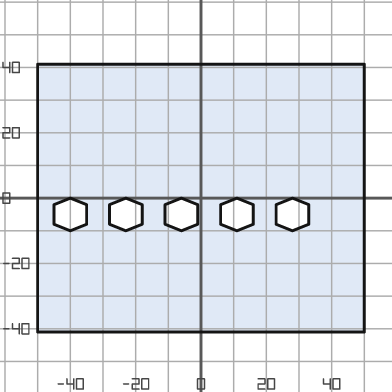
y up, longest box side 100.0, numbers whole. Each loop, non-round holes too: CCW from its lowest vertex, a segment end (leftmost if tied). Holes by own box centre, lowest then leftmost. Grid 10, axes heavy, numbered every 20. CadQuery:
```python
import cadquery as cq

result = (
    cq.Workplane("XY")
    .moveTo(-50.0, -41.0)
    .lineTo(50.0, -41.0)
    .lineTo(50.0, 41.0)
    .lineTo(-50.0, 41.0)
    .close()
    .moveTo(-40.0, -10.0)
    .lineTo(-35.0, -8.0)
    .lineTo(-35.0, -2.0)
    .lineTo(-40.0, 0.0)
    .lineTo(-45.0, -2.0)
    .lineTo(-45.0, -8.0)
    .close()
    .moveTo(-23.0, -10.0)
    .lineTo(-18.0, -8.0)
    .lineTo(-18.0, -2.0)
    .lineTo(-23.0, 0.0)
    .lineTo(-28.0, -2.0)
    .lineTo(-28.0, -8.0)
    .close()
    .moveTo(-6.0, -10.0)
    .lineTo(-1.0, -8.0)
    .lineTo(-1.0, -2.0)
    .lineTo(-6.0, 0.0)
    .lineTo(-11.0, -2.0)
    .lineTo(-11.0, -8.0)
    .close()
    .moveTo(11.0, -10.0)
    .lineTo(16.0, -8.0)
    .lineTo(16.0, -2.0)
    .lineTo(11.0, 0.0)
    .lineTo(6.0, -2.0)
    .lineTo(6.0, -8.0)
    .close()
    .moveTo(28.0, -10.0)
    .lineTo(33.0, -8.0)
    .lineTo(33.0, -2.0)
    .lineTo(28.0, 0.0)
    .lineTo(23.0, -2.0)
    .lineTo(23.0, -8.0)
    .close()
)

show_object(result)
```